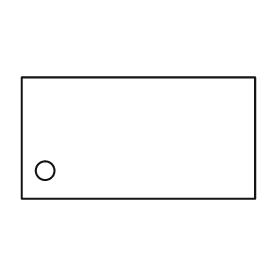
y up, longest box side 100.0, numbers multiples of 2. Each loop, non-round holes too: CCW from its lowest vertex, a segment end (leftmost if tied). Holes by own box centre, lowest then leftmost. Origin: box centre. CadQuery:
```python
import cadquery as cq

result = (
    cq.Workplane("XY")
    .moveTo(-50.0, -26.0)
    .lineTo(50.0, -26.0)
    .lineTo(50.0, 26.0)
    .lineTo(-50.0, 26.0)
    .close()
    .moveTo(-40.0, -14.0)
    .circle(4.0)
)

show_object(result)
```